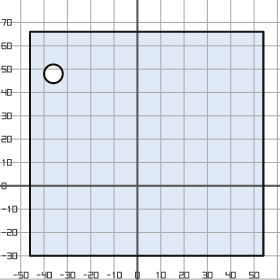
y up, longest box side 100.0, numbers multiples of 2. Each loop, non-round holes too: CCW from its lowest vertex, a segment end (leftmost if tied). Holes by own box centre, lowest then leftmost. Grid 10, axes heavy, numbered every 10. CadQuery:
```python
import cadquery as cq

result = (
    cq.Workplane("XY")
    .moveTo(-46.0, -30.0)
    .lineTo(54.0, -30.0)
    .lineTo(54.0, 66.0)
    .lineTo(-46.0, 66.0)
    .close()
    .moveTo(-36.0, 48.0)
    .circle(4.0)
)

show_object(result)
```